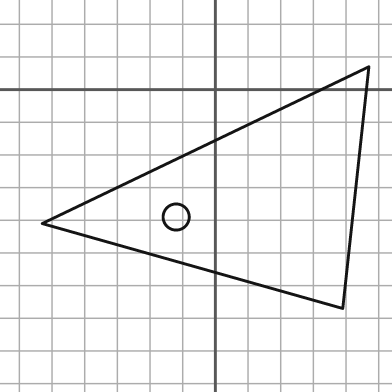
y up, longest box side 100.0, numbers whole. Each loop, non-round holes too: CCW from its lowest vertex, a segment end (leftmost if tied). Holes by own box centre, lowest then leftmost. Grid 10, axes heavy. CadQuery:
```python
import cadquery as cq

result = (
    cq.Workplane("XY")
    .moveTo(39.0, -67.0)
    .lineTo(47.0, 7.0)
    .lineTo(-53.0, -41.0)
    .close()
    .moveTo(-12.0, -39.0)
    .circle(4.0)
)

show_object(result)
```